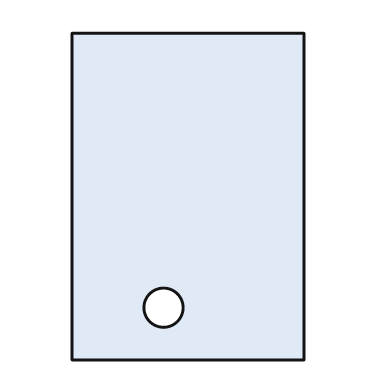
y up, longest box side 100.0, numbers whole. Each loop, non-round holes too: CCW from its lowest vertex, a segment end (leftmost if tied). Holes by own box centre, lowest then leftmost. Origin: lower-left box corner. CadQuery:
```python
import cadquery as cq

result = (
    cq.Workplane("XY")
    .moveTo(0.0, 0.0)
    .lineTo(71.0, 0.0)
    .lineTo(71.0, 100.0)
    .lineTo(0.0, 100.0)
    .close()
    .moveTo(28.0, 16.0)
    .circle(6.0)
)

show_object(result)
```